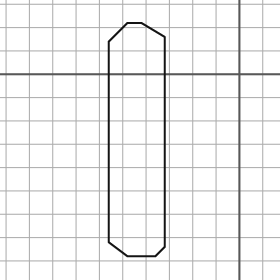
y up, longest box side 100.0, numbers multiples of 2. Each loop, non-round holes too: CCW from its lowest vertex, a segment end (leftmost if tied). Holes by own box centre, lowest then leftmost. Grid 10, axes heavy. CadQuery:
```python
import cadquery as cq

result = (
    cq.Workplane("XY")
    .moveTo(-48.0, -78.0)
    .lineTo(-36.0, -78.0)
    .lineTo(-32.0, -74.0)
    .lineTo(-32.0, 16.0)
    .lineTo(-42.0, 22.0)
    .lineTo(-48.0, 22.0)
    .lineTo(-56.0, 14.0)
    .lineTo(-56.0, -72.0)
    .close()
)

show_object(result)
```